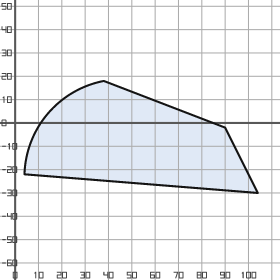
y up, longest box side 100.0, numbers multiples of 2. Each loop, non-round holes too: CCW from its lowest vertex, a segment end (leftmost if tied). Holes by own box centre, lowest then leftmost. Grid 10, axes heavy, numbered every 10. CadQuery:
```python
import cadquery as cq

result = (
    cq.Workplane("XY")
    .moveTo(104.0, -30.0)
    .lineTo(90.0, -2.0)
    .lineTo(38.0, 18.0)
    .threePointArc((14.0, 4.0), (4.0, -22.0))
    .close()
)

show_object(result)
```